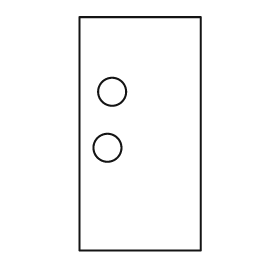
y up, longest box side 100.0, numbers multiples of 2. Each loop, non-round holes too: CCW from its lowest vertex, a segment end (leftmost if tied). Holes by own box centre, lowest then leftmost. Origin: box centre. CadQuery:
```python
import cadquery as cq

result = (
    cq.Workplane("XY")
    .moveTo(-26.0, -50.0)
    .lineTo(26.0, -50.0)
    .lineTo(26.0, 50.0)
    .lineTo(-26.0, 50.0)
    .close()
    .moveTo(-14.0, -6.0)
    .circle(6.0)
    .moveTo(-12.0, 18.0)
    .circle(6.0)
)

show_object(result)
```